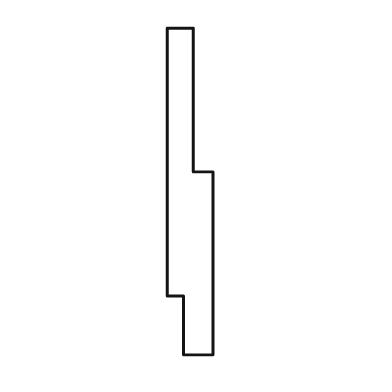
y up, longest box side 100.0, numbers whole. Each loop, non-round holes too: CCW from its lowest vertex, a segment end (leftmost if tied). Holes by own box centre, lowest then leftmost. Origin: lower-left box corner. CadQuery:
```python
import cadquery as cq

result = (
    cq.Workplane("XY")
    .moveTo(5.0, 0.0)
    .lineTo(14.0, 0.0)
    .lineTo(14.0, 56.0)
    .lineTo(8.0, 56.0)
    .lineTo(8.0, 100.0)
    .lineTo(0.0, 100.0)
    .lineTo(0.0, 18.0)
    .lineTo(5.0, 18.0)
    .close()
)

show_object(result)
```